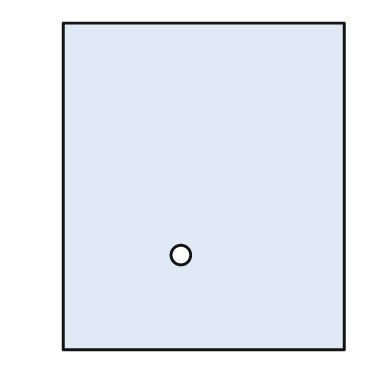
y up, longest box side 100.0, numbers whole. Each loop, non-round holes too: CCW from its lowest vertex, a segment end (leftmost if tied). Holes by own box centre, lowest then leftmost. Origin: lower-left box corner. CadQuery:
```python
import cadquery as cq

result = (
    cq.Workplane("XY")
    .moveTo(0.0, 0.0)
    .lineTo(86.0, 0.0)
    .lineTo(86.0, 100.0)
    .lineTo(0.0, 100.0)
    .close()
    .moveTo(36.0, 29.0)
    .circle(3.0)
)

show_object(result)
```